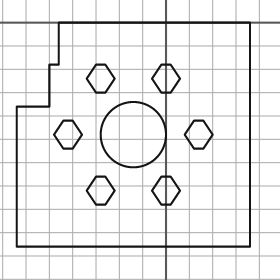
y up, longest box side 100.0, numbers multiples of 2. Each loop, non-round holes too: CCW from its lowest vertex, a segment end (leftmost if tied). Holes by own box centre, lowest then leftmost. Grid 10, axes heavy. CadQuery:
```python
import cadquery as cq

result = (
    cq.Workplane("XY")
    .moveTo(-64.0, -96.0)
    .lineTo(36.0, -96.0)
    .lineTo(36.0, 0.0)
    .lineTo(-46.0, 0.0)
    .lineTo(-46.0, -18.0)
    .lineTo(-50.0, -18.0)
    .lineTo(-50.0, -36.0)
    .lineTo(-64.0, -36.0)
    .close()
    .moveTo(-30.0, -78.0)
    .lineTo(-26.0, -78.0)
    .lineTo(-22.0, -72.0)
    .lineTo(-26.0, -66.0)
    .lineTo(-30.0, -66.0)
    .lineTo(-34.0, -72.0)
    .close()
    .moveTo(-2.0, -78.0)
    .lineTo(2.0, -78.0)
    .lineTo(6.0, -72.0)
    .lineTo(2.0, -66.0)
    .lineTo(-2.0, -66.0)
    .lineTo(-6.0, -72.0)
    .close()
    .moveTo(-44.0, -54.0)
    .lineTo(-40.0, -54.0)
    .lineTo(-36.0, -48.0)
    .lineTo(-40.0, -42.0)
    .lineTo(-44.0, -42.0)
    .lineTo(-48.0, -48.0)
    .close()
    .moveTo(-14.0, -48.0)
    .circle(14.0)
    .moveTo(12.0, -54.0)
    .lineTo(16.0, -54.0)
    .lineTo(20.0, -48.0)
    .lineTo(16.0, -42.0)
    .lineTo(12.0, -42.0)
    .lineTo(8.0, -48.0)
    .close()
    .moveTo(-30.0, -30.0)
    .lineTo(-26.0, -30.0)
    .lineTo(-22.0, -24.0)
    .lineTo(-26.0, -18.0)
    .lineTo(-30.0, -18.0)
    .lineTo(-34.0, -24.0)
    .close()
    .moveTo(-2.0, -30.0)
    .lineTo(2.0, -30.0)
    .lineTo(6.0, -24.0)
    .lineTo(2.0, -18.0)
    .lineTo(-2.0, -18.0)
    .lineTo(-6.0, -24.0)
    .close()
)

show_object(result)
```